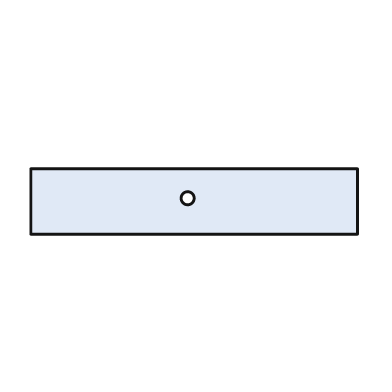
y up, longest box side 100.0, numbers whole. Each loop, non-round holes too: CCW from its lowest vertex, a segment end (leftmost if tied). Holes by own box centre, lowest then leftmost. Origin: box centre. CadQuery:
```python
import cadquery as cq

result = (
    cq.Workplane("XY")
    .moveTo(-50.0, -10.0)
    .lineTo(50.0, -10.0)
    .lineTo(50.0, 10.0)
    .lineTo(-50.0, 10.0)
    .close()
    .moveTo(-2.0, 1.0)
    .circle(2.0)
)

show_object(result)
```